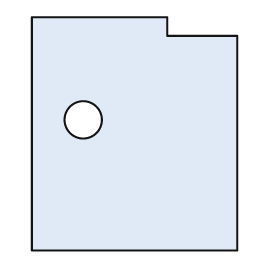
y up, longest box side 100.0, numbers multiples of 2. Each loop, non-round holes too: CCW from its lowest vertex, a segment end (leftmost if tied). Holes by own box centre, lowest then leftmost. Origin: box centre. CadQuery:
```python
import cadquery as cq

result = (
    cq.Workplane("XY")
    .moveTo(-44.0, -50.0)
    .lineTo(44.0, -50.0)
    .lineTo(44.0, 42.0)
    .lineTo(14.0, 42.0)
    .lineTo(14.0, 50.0)
    .lineTo(-44.0, 50.0)
    .close()
    .moveTo(-22.0, 6.0)
    .circle(8.0)
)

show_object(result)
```